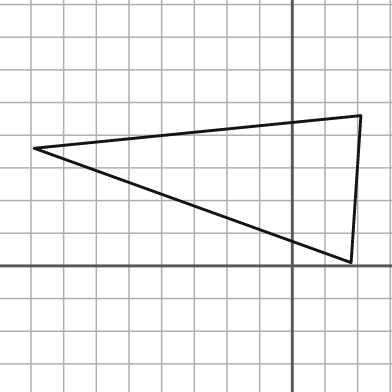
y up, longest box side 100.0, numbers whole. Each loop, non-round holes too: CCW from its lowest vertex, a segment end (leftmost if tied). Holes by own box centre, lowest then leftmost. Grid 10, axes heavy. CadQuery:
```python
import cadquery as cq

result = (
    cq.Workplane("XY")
    .moveTo(18.0, 1.0)
    .lineTo(21.0, 46.0)
    .lineTo(-79.0, 36.0)
    .close()
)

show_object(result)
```